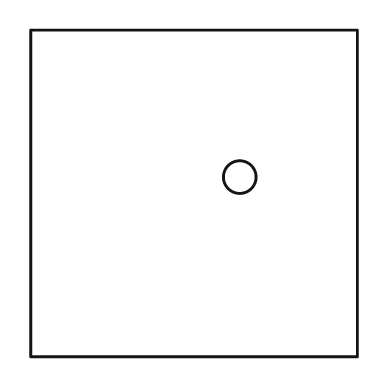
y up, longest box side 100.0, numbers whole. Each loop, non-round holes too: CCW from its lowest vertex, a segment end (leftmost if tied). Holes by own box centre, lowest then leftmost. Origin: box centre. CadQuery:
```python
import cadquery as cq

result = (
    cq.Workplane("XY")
    .moveTo(-50.0, -50.0)
    .lineTo(50.0, -50.0)
    .lineTo(50.0, 50.0)
    .lineTo(-50.0, 50.0)
    .close()
    .moveTo(14.0, 5.0)
    .circle(5.0)
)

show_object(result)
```